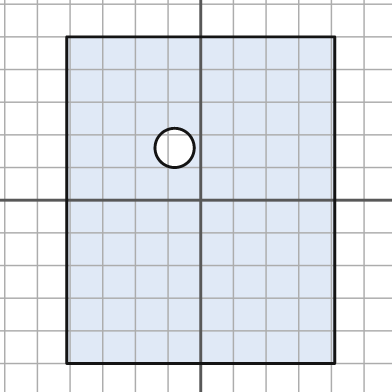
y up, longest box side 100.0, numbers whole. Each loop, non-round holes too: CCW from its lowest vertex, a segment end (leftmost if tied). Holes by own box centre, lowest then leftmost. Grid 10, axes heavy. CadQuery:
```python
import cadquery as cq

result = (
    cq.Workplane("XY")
    .moveTo(-41.0, -50.0)
    .lineTo(41.0, -50.0)
    .lineTo(41.0, 50.0)
    .lineTo(-41.0, 50.0)
    .close()
    .moveTo(-8.0, 16.0)
    .circle(6.0)
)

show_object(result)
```